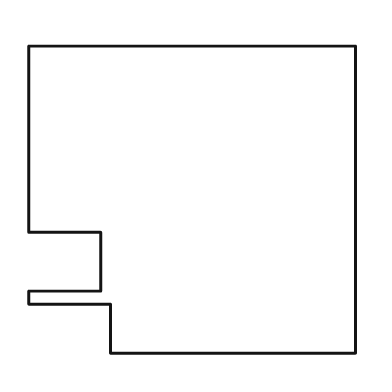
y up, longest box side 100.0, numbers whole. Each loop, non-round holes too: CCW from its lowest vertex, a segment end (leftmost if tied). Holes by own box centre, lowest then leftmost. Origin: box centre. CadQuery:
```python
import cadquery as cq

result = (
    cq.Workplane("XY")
    .moveTo(-25.0, -47.0)
    .lineTo(50.0, -47.0)
    .lineTo(50.0, 47.0)
    .lineTo(-50.0, 47.0)
    .lineTo(-50.0, -10.0)
    .lineTo(-28.0, -10.0)
    .lineTo(-28.0, -28.0)
    .lineTo(-50.0, -28.0)
    .lineTo(-50.0, -32.0)
    .lineTo(-25.0, -32.0)
    .close()
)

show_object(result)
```